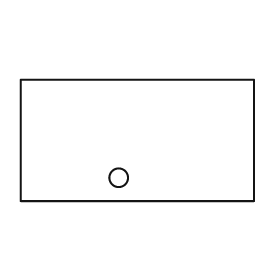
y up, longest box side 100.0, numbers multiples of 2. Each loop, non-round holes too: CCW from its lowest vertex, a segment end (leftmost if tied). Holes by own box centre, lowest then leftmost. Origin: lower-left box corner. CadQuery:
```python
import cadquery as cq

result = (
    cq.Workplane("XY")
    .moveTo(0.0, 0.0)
    .lineTo(100.0, 0.0)
    .lineTo(100.0, 52.0)
    .lineTo(0.0, 52.0)
    .close()
    .moveTo(42.0, 10.0)
    .circle(4.0)
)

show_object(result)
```